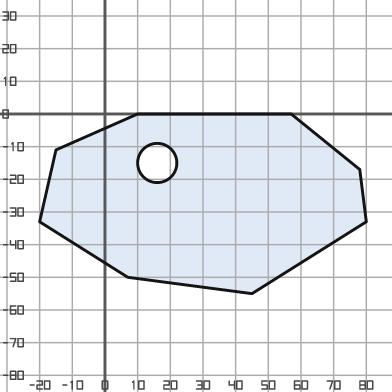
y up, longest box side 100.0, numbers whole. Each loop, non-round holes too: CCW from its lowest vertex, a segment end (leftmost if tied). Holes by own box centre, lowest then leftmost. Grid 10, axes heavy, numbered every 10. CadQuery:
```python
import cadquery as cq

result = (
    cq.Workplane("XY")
    .moveTo(45.0, -55.0)
    .lineTo(80.0, -33.0)
    .lineTo(78.0, -17.0)
    .lineTo(57.0, 0.0)
    .lineTo(10.0, 0.0)
    .lineTo(-15.0, -11.0)
    .lineTo(-20.0, -33.0)
    .lineTo(7.0, -50.0)
    .close()
    .moveTo(16.0, -15.0)
    .circle(6.0)
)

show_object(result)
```